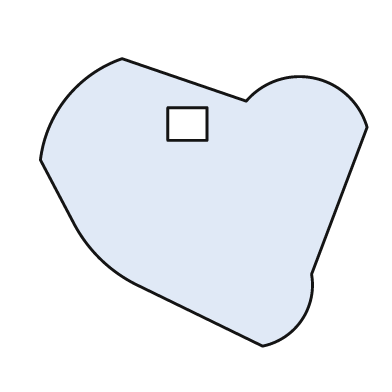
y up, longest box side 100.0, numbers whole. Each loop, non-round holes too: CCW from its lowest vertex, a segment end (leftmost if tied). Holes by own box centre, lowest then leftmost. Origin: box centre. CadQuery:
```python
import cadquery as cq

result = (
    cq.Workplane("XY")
    .moveTo(18.0, -44.0)
    .threePointArc((30.0, -36.0), (33.0, -22.0))
    .lineTo(50.0, 23.0)
    .threePointArc((34.0, 38.0), (13.0, 31.0))
    .lineTo(-25.0, 44.0)
    .threePointArc((-42.0, 32.0), (-50.0, 13.0))
    .lineTo(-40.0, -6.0)
    .threePointArc((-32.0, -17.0), (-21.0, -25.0))
    .close()
    .moveTo(-11.0, 19.0)
    .lineTo(1.0, 19.0)
    .lineTo(1.0, 29.0)
    .lineTo(-11.0, 29.0)
    .close()
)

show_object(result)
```